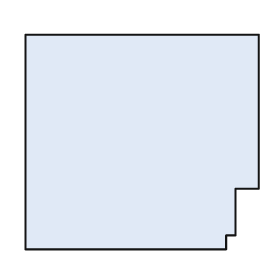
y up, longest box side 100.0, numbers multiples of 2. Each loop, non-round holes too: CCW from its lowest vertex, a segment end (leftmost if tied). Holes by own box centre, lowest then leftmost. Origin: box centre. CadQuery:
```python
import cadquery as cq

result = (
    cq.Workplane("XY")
    .moveTo(-50.0, -46.0)
    .lineTo(36.0, -46.0)
    .lineTo(36.0, -40.0)
    .lineTo(40.0, -40.0)
    .lineTo(40.0, -20.0)
    .lineTo(50.0, -20.0)
    .lineTo(50.0, 46.0)
    .lineTo(-50.0, 46.0)
    .close()
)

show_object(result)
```